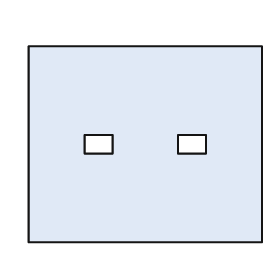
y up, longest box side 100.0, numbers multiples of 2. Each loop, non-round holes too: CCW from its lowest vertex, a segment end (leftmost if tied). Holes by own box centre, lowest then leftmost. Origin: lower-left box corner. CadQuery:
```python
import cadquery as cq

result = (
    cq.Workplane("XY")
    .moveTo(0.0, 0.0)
    .lineTo(100.0, 0.0)
    .lineTo(100.0, 84.0)
    .lineTo(0.0, 84.0)
    .close()
    .moveTo(24.0, 38.0)
    .lineTo(36.0, 38.0)
    .lineTo(36.0, 46.0)
    .lineTo(24.0, 46.0)
    .close()
    .moveTo(64.0, 38.0)
    .lineTo(76.0, 38.0)
    .lineTo(76.0, 46.0)
    .lineTo(64.0, 46.0)
    .close()
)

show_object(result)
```